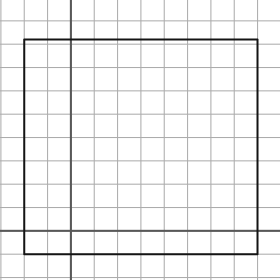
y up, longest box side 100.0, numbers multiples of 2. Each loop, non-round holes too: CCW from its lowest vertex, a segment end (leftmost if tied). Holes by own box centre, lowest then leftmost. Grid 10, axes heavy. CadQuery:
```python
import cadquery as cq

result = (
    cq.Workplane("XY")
    .moveTo(-20.0, -10.0)
    .lineTo(80.0, -10.0)
    .lineTo(80.0, 82.0)
    .lineTo(-20.0, 82.0)
    .close()
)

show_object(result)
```